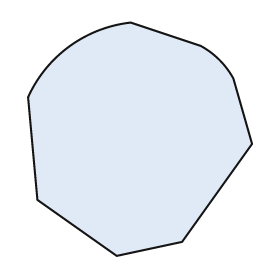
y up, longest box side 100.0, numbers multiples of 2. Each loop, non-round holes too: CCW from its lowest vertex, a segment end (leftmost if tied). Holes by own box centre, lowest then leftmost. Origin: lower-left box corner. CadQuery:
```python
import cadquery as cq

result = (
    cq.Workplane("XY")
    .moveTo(38.0, 0.0)
    .lineTo(66.0, 6.0)
    .lineTo(96.0, 48.0)
    .lineTo(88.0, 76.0)
    .threePointArc((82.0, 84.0), (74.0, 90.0))
    .lineTo(44.0, 100.0)
    .threePointArc((18.0, 90.0), (0.0, 68.0))
    .lineTo(4.0, 24.0)
    .close()
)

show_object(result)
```